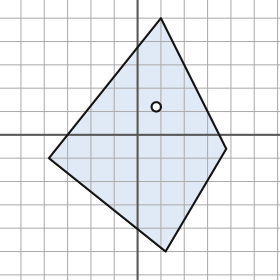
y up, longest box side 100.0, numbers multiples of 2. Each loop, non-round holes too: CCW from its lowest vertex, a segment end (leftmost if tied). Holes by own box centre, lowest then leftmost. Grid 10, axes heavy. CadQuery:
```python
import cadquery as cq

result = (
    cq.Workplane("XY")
    .moveTo(12.0, -50.0)
    .lineTo(38.0, -6.0)
    .lineTo(10.0, 50.0)
    .lineTo(-38.0, -10.0)
    .close()
    .moveTo(8.0, 12.0)
    .circle(2.0)
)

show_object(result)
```